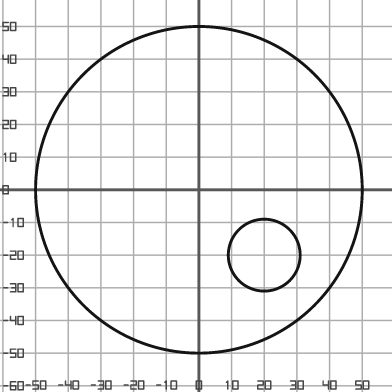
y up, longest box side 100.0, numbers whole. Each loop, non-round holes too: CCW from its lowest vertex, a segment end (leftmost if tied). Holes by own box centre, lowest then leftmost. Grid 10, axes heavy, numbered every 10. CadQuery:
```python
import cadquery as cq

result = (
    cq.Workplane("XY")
    .moveTo(0.0, 0.0)
    .circle(50.0)
    .moveTo(20.0, -20.0)
    .circle(11.0)
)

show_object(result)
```